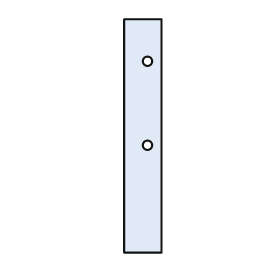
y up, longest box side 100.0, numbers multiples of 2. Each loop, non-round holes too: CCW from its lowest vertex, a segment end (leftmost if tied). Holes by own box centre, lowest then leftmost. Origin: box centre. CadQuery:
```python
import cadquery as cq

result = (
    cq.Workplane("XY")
    .moveTo(-8.0, -50.0)
    .lineTo(8.0, -50.0)
    .lineTo(8.0, 50.0)
    .lineTo(-8.0, 50.0)
    .close()
    .moveTo(2.0, -4.0)
    .circle(2.0)
    .moveTo(2.0, 32.0)
    .circle(2.0)
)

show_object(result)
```